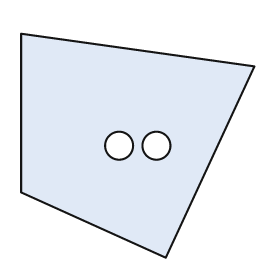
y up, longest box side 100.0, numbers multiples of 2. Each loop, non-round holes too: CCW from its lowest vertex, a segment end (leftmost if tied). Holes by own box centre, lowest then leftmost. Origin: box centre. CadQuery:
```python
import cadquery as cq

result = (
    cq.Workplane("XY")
    .moveTo(12.0, -48.0)
    .lineTo(50.0, 34.0)
    .lineTo(-50.0, 48.0)
    .lineTo(-50.0, -20.0)
    .close()
    .moveTo(-8.0, 0.0)
    .circle(6.0)
    .moveTo(8.0, 0.0)
    .circle(6.0)
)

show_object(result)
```